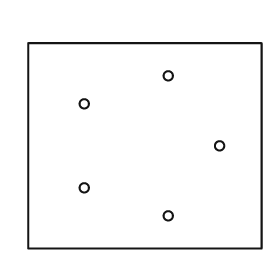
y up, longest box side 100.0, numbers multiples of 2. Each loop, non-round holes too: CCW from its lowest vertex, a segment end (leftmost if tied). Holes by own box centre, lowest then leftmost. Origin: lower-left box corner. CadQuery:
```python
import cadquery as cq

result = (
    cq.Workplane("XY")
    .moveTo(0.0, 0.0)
    .lineTo(100.0, 0.0)
    .lineTo(100.0, 88.0)
    .lineTo(0.0, 88.0)
    .close()
    .moveTo(60.0, 14.0)
    .circle(2.0)
    .moveTo(24.0, 26.0)
    .circle(2.0)
    .moveTo(82.0, 44.0)
    .circle(2.0)
    .moveTo(24.0, 62.0)
    .circle(2.0)
    .moveTo(60.0, 74.0)
    .circle(2.0)
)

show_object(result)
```